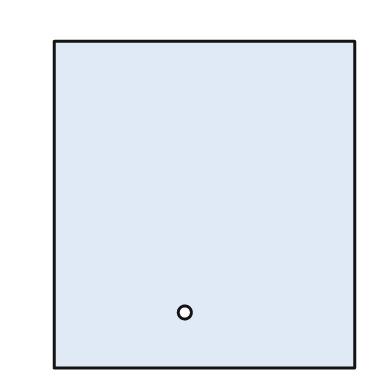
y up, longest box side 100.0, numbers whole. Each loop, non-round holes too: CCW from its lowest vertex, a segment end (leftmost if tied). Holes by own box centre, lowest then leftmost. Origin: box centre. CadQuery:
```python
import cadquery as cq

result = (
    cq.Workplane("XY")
    .moveTo(-46.0, -50.0)
    .lineTo(46.0, -50.0)
    .lineTo(46.0, 50.0)
    .lineTo(-46.0, 50.0)
    .close()
    .moveTo(-6.0, -33.0)
    .circle(2.0)
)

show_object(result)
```